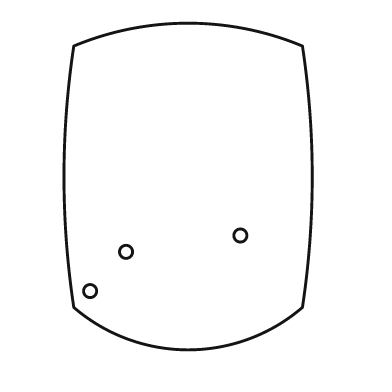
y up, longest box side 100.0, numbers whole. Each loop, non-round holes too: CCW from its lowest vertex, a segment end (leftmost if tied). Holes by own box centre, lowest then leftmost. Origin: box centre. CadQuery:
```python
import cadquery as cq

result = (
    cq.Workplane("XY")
    .moveTo(-35.0, -37.0)
    .threePointArc((0.0, -50.0), (35.0, -37.0))
    .threePointArc((38.0, 3.0), (35.0, 43.0))
    .threePointArc((0.0, 50.0), (-35.0, 43.0))
    .threePointArc((-38.0, 3.0), (-35.0, -37.0))
    .close()
    .moveTo(-30.0, -32.0)
    .circle(2.0)
    .moveTo(-19.0, -20.0)
    .circle(2.0)
    .moveTo(16.0, -15.0)
    .circle(2.0)
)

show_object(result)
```